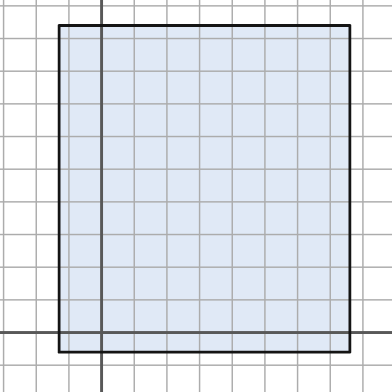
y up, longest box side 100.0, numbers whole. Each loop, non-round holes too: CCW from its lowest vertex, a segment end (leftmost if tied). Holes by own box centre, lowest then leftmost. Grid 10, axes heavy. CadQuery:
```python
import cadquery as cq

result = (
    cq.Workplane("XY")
    .moveTo(-13.0, -6.0)
    .lineTo(76.0, -6.0)
    .lineTo(76.0, 94.0)
    .lineTo(-13.0, 94.0)
    .close()
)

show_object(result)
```